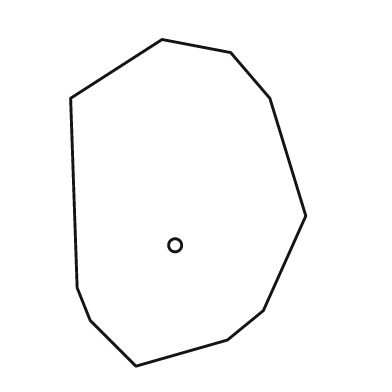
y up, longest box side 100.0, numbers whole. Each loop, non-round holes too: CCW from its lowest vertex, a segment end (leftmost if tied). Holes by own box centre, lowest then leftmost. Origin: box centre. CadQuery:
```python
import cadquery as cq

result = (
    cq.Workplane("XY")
    .moveTo(-16.0, -50.0)
    .lineTo(12.0, -42.0)
    .lineTo(23.0, -33.0)
    .lineTo(36.0, -4.0)
    .lineTo(25.0, 32.0)
    .lineTo(13.0, 46.0)
    .lineTo(-8.0, 50.0)
    .lineTo(-36.0, 32.0)
    .lineTo(-34.0, -26.0)
    .lineTo(-30.0, -36.0)
    .close()
    .moveTo(-4.0, -13.0)
    .circle(2.0)
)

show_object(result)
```